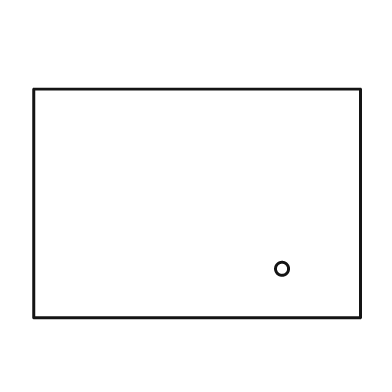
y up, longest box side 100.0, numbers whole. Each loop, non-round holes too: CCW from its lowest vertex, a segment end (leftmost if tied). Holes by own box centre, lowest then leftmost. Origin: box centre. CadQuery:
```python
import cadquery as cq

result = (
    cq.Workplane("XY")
    .moveTo(-50.0, -35.0)
    .lineTo(50.0, -35.0)
    .lineTo(50.0, 35.0)
    .lineTo(-50.0, 35.0)
    .close()
    .moveTo(26.0, -20.0)
    .circle(2.0)
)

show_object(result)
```